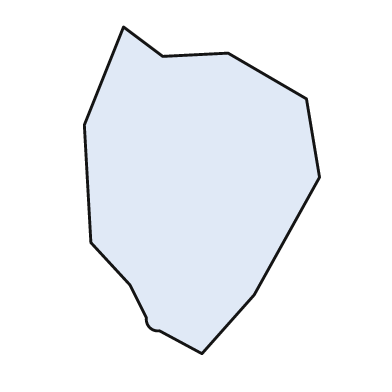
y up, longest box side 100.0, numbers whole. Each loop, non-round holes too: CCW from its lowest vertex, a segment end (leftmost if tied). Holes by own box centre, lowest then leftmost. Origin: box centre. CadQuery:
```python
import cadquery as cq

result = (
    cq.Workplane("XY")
    .moveTo(0.0, -50.0)
    .lineTo(16.0, -32.0)
    .lineTo(36.0, 4.0)
    .lineTo(32.0, 28.0)
    .lineTo(8.0, 42.0)
    .lineTo(-12.0, 41.0)
    .lineTo(-24.0, 50.0)
    .lineTo(-36.0, 20.0)
    .lineTo(-34.0, -16.0)
    .lineTo(-22.0, -29.0)
    .lineTo(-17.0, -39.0)
    .threePointArc((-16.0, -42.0), (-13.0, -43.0))
    .close()
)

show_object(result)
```